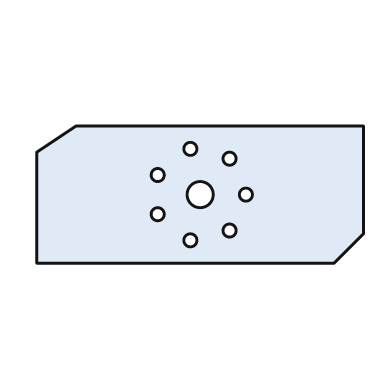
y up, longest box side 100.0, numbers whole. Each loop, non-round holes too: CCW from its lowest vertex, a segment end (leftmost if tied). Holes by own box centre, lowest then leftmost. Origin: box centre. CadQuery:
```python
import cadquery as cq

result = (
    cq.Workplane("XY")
    .moveTo(-50.0, -21.0)
    .lineTo(41.0, -21.0)
    .lineTo(50.0, -12.0)
    .lineTo(50.0, 21.0)
    .lineTo(-38.0, 21.0)
    .lineTo(-50.0, 13.0)
    .close()
    .moveTo(-3.0, -14.0)
    .circle(2.0)
    .moveTo(9.0, -11.0)
    .circle(2.0)
    .moveTo(-13.0, -6.0)
    .circle(2.0)
    .moveTo(0.0, 0.0)
    .circle(4.0)
    .moveTo(14.0, 0.0)
    .circle(2.0)
    .moveTo(-13.0, 6.0)
    .circle(2.0)
    .moveTo(9.0, 11.0)
    .circle(2.0)
    .moveTo(-3.0, 14.0)
    .circle(2.0)
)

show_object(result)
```